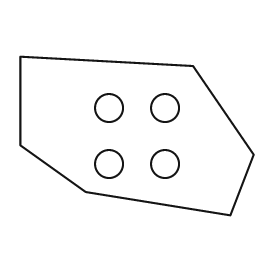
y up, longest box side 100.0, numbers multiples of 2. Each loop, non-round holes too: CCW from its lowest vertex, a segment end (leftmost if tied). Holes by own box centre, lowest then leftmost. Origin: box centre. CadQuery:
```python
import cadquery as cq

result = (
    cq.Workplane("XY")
    .moveTo(40.0, -34.0)
    .lineTo(50.0, -8.0)
    .lineTo(24.0, 30.0)
    .lineTo(-50.0, 34.0)
    .lineTo(-50.0, -4.0)
    .lineTo(-22.0, -24.0)
    .close()
    .moveTo(-12.0, -12.0)
    .circle(6.0)
    .moveTo(12.0, -12.0)
    .circle(6.0)
    .moveTo(-12.0, 12.0)
    .circle(6.0)
    .moveTo(12.0, 12.0)
    .circle(6.0)
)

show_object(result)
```